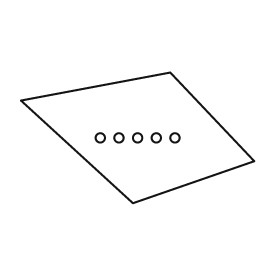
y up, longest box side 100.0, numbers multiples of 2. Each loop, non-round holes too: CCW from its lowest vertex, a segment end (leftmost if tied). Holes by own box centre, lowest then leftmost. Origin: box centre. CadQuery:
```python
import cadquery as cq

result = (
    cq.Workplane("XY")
    .moveTo(-2.0, -28.0)
    .lineTo(50.0, -10.0)
    .lineTo(14.0, 28.0)
    .lineTo(-50.0, 16.0)
    .close()
    .moveTo(-16.0, 0.0)
    .circle(2.0)
    .moveTo(-8.0, 0.0)
    .circle(2.0)
    .moveTo(0.0, 0.0)
    .circle(2.0)
    .moveTo(8.0, 0.0)
    .circle(2.0)
    .moveTo(16.0, 0.0)
    .circle(2.0)
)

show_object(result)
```